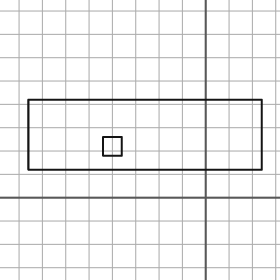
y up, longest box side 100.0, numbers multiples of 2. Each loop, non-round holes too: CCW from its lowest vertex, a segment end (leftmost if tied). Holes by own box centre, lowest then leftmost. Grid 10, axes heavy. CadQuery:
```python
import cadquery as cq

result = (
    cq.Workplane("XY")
    .moveTo(-76.0, 12.0)
    .lineTo(24.0, 12.0)
    .lineTo(24.0, 42.0)
    .lineTo(-76.0, 42.0)
    .close()
    .moveTo(-44.0, 18.0)
    .lineTo(-36.0, 18.0)
    .lineTo(-36.0, 26.0)
    .lineTo(-44.0, 26.0)
    .close()
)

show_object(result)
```